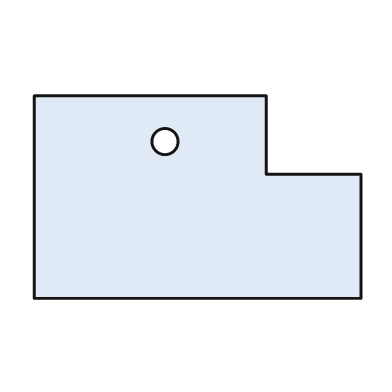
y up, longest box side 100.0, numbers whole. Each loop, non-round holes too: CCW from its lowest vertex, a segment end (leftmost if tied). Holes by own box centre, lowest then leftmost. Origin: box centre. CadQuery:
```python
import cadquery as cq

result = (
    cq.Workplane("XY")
    .moveTo(-50.0, -31.0)
    .lineTo(50.0, -31.0)
    .lineTo(50.0, 7.0)
    .lineTo(21.0, 7.0)
    .lineTo(21.0, 31.0)
    .lineTo(-50.0, 31.0)
    .close()
    .moveTo(-10.0, 17.0)
    .circle(4.0)
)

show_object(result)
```